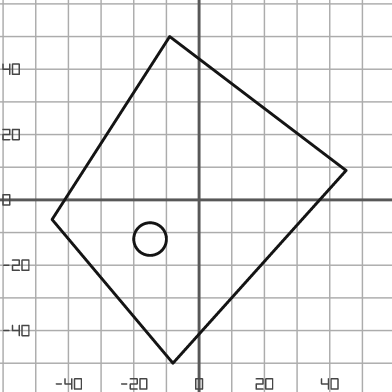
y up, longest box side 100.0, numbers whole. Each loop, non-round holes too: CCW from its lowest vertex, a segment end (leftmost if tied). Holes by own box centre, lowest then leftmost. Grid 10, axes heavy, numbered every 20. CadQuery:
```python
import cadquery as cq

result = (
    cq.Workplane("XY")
    .moveTo(-8.0, -50.0)
    .lineTo(45.0, 9.0)
    .lineTo(-9.0, 50.0)
    .lineTo(-45.0, -6.0)
    .close()
    .moveTo(-15.0, -12.0)
    .circle(5.0)
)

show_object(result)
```